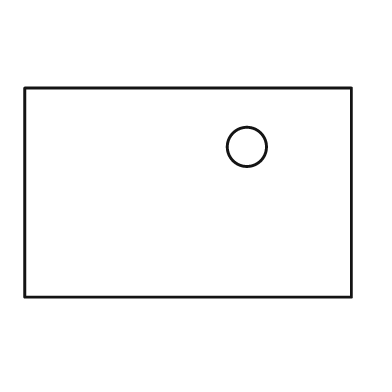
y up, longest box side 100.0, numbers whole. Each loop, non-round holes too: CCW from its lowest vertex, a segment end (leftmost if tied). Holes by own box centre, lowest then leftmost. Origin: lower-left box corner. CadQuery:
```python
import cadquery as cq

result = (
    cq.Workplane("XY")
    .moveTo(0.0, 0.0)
    .lineTo(100.0, 0.0)
    .lineTo(100.0, 64.0)
    .lineTo(0.0, 64.0)
    .close()
    .moveTo(68.0, 46.0)
    .circle(6.0)
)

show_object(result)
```